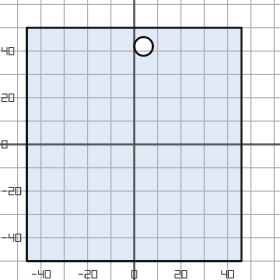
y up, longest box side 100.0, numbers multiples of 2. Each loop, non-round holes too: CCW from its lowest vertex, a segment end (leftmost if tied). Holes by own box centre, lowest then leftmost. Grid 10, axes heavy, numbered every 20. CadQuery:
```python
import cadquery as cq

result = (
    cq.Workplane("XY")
    .moveTo(-46.0, -50.0)
    .lineTo(46.0, -50.0)
    .lineTo(46.0, 50.0)
    .lineTo(-46.0, 50.0)
    .close()
    .moveTo(4.0, 42.0)
    .circle(4.0)
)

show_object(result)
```